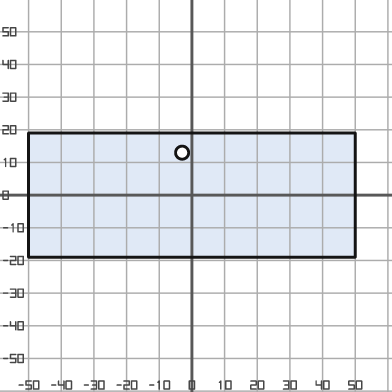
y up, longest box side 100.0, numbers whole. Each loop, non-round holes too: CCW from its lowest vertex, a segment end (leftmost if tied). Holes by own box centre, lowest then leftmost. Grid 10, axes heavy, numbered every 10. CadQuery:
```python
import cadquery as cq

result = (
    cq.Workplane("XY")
    .moveTo(-50.0, -19.0)
    .lineTo(50.0, -19.0)
    .lineTo(50.0, 19.0)
    .lineTo(-50.0, 19.0)
    .close()
    .moveTo(-3.0, 13.0)
    .circle(2.0)
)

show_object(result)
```